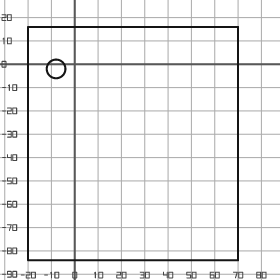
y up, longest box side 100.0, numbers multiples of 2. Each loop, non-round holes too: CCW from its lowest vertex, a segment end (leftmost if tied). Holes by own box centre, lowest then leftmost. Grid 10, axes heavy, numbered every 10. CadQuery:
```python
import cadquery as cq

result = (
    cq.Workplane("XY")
    .moveTo(-20.0, -84.0)
    .lineTo(70.0, -84.0)
    .lineTo(70.0, 16.0)
    .lineTo(-20.0, 16.0)
    .close()
    .moveTo(-8.0, -2.0)
    .circle(4.0)
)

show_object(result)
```